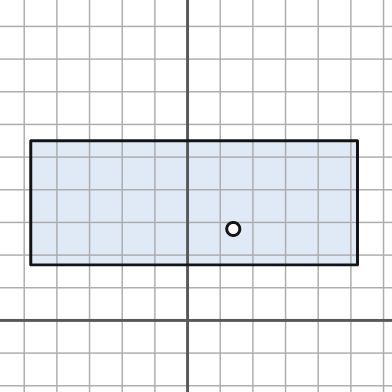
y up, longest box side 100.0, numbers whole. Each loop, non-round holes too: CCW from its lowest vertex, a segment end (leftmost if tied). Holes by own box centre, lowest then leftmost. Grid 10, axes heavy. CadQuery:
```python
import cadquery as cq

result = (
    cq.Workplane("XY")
    .moveTo(-48.0, 17.0)
    .lineTo(52.0, 17.0)
    .lineTo(52.0, 55.0)
    .lineTo(-48.0, 55.0)
    .close()
    .moveTo(14.0, 28.0)
    .circle(2.0)
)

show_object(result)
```